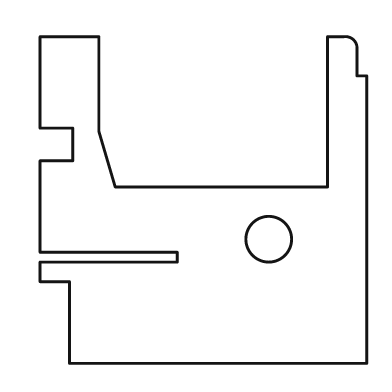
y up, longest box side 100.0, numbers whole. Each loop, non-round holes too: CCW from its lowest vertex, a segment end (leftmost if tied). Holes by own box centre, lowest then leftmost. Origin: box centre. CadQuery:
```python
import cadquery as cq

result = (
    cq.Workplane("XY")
    .moveTo(-41.0, -50.0)
    .lineTo(50.0, -50.0)
    .lineTo(50.0, 38.0)
    .lineTo(47.0, 38.0)
    .lineTo(47.0, 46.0)
    .threePointArc((46.0, 49.0), (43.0, 50.0))
    .lineTo(38.0, 50.0)
    .lineTo(38.0, 4.0)
    .lineTo(-27.0, 4.0)
    .lineTo(-32.0, 21.0)
    .lineTo(-32.0, 50.0)
    .lineTo(-50.0, 50.0)
    .lineTo(-50.0, 22.0)
    .lineTo(-40.0, 22.0)
    .lineTo(-40.0, 12.0)
    .lineTo(-50.0, 12.0)
    .lineTo(-50.0, -16.0)
    .lineTo(-8.0, -16.0)
    .lineTo(-8.0, -19.0)
    .lineTo(-50.0, -19.0)
    .lineTo(-50.0, -25.0)
    .lineTo(-41.0, -25.0)
    .close()
    .moveTo(20.0, -12.0)
    .circle(7.0)
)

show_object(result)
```